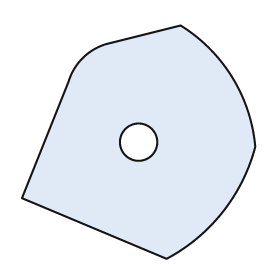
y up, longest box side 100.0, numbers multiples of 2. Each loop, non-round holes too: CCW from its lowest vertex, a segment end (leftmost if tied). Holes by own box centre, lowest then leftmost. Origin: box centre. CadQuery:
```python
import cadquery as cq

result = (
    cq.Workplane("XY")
    .moveTo(12.0, -50.0)
    .threePointArc((36.0, -30.0), (50.0, -2.0))
    .threePointArc((40.0, 28.0), (18.0, 50.0))
    .lineTo(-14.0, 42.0)
    .threePointArc((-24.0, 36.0), (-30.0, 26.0))
    .lineTo(-50.0, -24.0)
    .close()
    .moveTo(0.0, 0.0)
    .circle(8.0)
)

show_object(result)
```